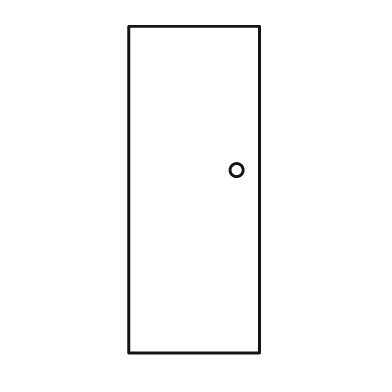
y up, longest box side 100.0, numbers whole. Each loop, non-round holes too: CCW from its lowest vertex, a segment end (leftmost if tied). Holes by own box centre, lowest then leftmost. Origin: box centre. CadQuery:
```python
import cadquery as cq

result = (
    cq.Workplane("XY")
    .moveTo(-20.0, -50.0)
    .lineTo(20.0, -50.0)
    .lineTo(20.0, 50.0)
    .lineTo(-20.0, 50.0)
    .close()
    .moveTo(13.0, 6.0)
    .circle(2.0)
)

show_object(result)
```